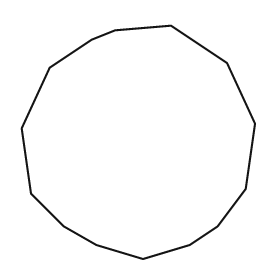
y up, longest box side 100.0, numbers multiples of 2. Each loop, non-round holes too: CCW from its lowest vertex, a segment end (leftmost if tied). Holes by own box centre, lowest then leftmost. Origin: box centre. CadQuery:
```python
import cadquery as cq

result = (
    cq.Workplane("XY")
    .moveTo(2.0, -50.0)
    .lineTo(22.0, -44.0)
    .lineTo(34.0, -36.0)
    .lineTo(46.0, -20.0)
    .lineTo(50.0, 8.0)
    .lineTo(38.0, 34.0)
    .lineTo(14.0, 50.0)
    .lineTo(-10.0, 48.0)
    .lineTo(-20.0, 44.0)
    .lineTo(-38.0, 32.0)
    .lineTo(-50.0, 6.0)
    .lineTo(-46.0, -22.0)
    .lineTo(-32.0, -36.0)
    .lineTo(-18.0, -44.0)
    .close()
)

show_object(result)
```